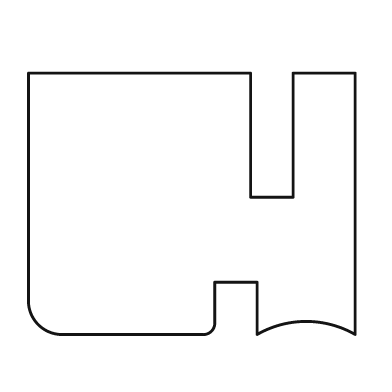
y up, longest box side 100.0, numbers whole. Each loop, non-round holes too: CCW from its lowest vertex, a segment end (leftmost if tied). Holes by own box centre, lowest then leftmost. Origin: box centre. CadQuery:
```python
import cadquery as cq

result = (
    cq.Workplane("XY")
    .moveTo(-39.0, -40.0)
    .lineTo(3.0, -40.0)
    .threePointArc((6.0, -39.0), (7.0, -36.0))
    .lineTo(7.0, -24.0)
    .lineTo(20.0, -24.0)
    .lineTo(20.0, -40.0)
    .threePointArc((35.0, -36.0), (50.0, -40.0))
    .lineTo(50.0, 40.0)
    .lineTo(31.0, 40.0)
    .lineTo(31.0, 2.0)
    .lineTo(18.0, 2.0)
    .lineTo(18.0, 40.0)
    .lineTo(-50.0, 40.0)
    .lineTo(-50.0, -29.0)
    .threePointArc((-47.0, -37.0), (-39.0, -40.0))
    .close()
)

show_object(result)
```